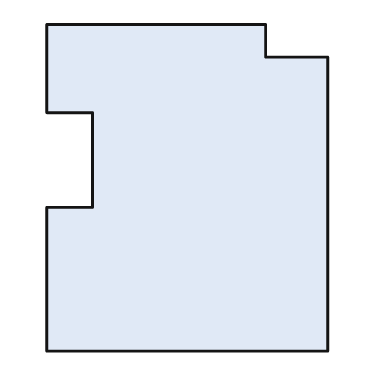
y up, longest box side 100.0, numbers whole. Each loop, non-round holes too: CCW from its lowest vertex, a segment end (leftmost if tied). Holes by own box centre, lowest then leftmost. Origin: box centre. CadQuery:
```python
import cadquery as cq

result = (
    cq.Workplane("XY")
    .moveTo(-43.0, -50.0)
    .lineTo(43.0, -50.0)
    .lineTo(43.0, 40.0)
    .lineTo(24.0, 40.0)
    .lineTo(24.0, 50.0)
    .lineTo(-43.0, 50.0)
    .lineTo(-43.0, 23.0)
    .lineTo(-29.0, 23.0)
    .lineTo(-29.0, -6.0)
    .lineTo(-43.0, -6.0)
    .close()
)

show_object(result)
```